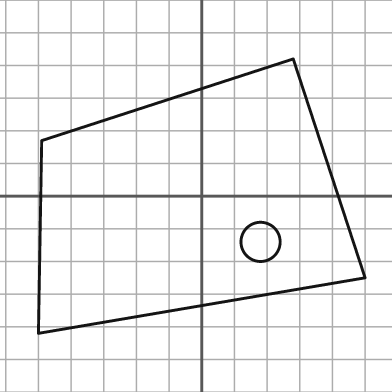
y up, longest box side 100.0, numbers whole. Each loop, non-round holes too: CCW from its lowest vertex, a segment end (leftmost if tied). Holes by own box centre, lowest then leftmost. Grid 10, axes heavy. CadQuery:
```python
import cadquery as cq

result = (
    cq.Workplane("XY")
    .moveTo(-50.0, -42.0)
    .lineTo(50.0, -25.0)
    .lineTo(28.0, 42.0)
    .lineTo(-49.0, 17.0)
    .close()
    .moveTo(18.0, -14.0)
    .circle(6.0)
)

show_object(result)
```